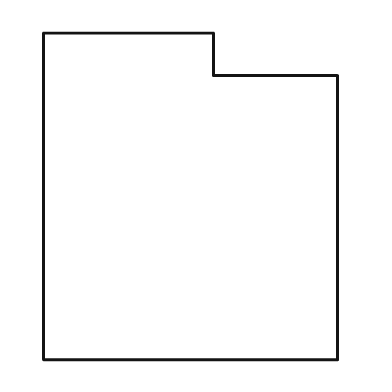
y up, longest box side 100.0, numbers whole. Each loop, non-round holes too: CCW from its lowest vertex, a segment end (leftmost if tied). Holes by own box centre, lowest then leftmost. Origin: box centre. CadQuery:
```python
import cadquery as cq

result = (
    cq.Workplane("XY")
    .moveTo(-45.0, -50.0)
    .lineTo(45.0, -50.0)
    .lineTo(45.0, 37.0)
    .lineTo(7.0, 37.0)
    .lineTo(7.0, 50.0)
    .lineTo(-45.0, 50.0)
    .close()
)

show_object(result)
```